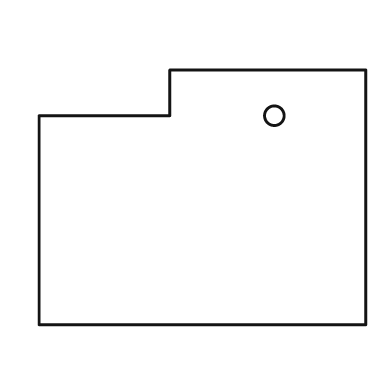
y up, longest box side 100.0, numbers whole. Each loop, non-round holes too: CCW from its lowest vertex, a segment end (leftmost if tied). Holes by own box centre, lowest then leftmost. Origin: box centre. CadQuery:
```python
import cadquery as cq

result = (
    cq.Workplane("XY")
    .moveTo(-50.0, -39.0)
    .lineTo(50.0, -39.0)
    .lineTo(50.0, 39.0)
    .lineTo(-10.0, 39.0)
    .lineTo(-10.0, 25.0)
    .lineTo(-50.0, 25.0)
    .close()
    .moveTo(22.0, 25.0)
    .circle(3.0)
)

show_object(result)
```